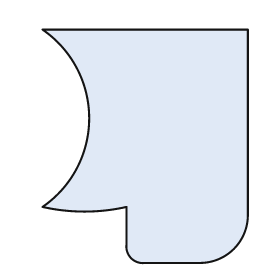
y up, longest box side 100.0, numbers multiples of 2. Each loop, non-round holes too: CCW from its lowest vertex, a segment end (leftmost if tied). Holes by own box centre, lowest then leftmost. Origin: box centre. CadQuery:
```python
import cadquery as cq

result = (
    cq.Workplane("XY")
    .moveTo(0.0, -50.0)
    .lineTo(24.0, -50.0)
    .threePointArc((38.0, -44.0), (44.0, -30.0))
    .lineTo(44.0, 50.0)
    .lineTo(-44.0, 50.0)
    .threePointArc((-24.0, 12.0), (-44.0, -26.0))
    .threePointArc((-26.0, -28.0), (-8.0, -26.0))
    .lineTo(-8.0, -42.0)
    .threePointArc((-6.0, -48.0), (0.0, -50.0))
    .close()
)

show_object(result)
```